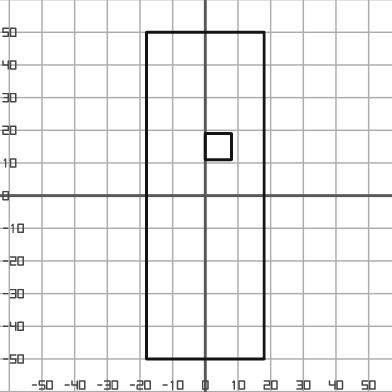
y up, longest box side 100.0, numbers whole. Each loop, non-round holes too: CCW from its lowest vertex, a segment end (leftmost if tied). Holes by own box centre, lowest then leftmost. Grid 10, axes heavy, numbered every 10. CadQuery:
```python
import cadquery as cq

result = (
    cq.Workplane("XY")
    .moveTo(-18.0, -50.0)
    .lineTo(18.0, -50.0)
    .lineTo(18.0, 50.0)
    .lineTo(-18.0, 50.0)
    .close()
    .moveTo(0.0, 11.0)
    .lineTo(8.0, 11.0)
    .lineTo(8.0, 19.0)
    .lineTo(0.0, 19.0)
    .close()
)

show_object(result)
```